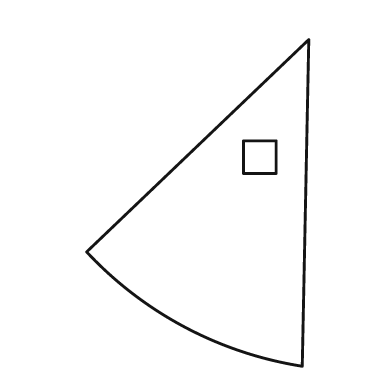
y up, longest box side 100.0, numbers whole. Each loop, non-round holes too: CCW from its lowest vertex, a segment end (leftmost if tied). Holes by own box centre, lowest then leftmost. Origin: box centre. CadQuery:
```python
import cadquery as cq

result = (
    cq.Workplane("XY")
    .moveTo(32.0, -50.0)
    .lineTo(34.0, 50.0)
    .lineTo(-34.0, -15.0)
    .threePointArc((-4.0, -38.0), (32.0, -50.0))
    .close()
    .moveTo(14.0, 9.0)
    .lineTo(24.0, 9.0)
    .lineTo(24.0, 19.0)
    .lineTo(14.0, 19.0)
    .close()
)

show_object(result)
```